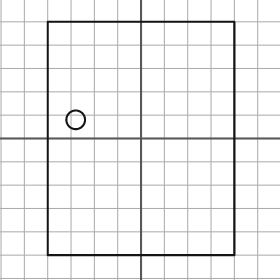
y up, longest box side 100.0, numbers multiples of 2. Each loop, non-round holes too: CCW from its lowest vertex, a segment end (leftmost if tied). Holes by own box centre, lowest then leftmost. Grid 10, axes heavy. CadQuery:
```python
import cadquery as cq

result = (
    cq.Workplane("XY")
    .moveTo(-40.0, -50.0)
    .lineTo(40.0, -50.0)
    .lineTo(40.0, 50.0)
    .lineTo(-40.0, 50.0)
    .close()
    .moveTo(-28.0, 8.0)
    .circle(4.0)
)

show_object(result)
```